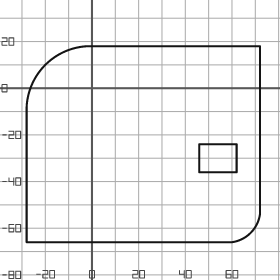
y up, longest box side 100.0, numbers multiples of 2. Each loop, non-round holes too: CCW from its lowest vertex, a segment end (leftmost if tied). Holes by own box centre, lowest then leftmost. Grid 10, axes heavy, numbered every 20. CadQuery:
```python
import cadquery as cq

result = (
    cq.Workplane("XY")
    .moveTo(-28.0, -66.0)
    .lineTo(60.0, -66.0)
    .threePointArc((68.0, -62.0), (72.0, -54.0))
    .lineTo(72.0, 18.0)
    .lineTo(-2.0, 18.0)
    .threePointArc((-20.0, 10.0), (-28.0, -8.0))
    .close()
    .moveTo(46.0, -36.0)
    .lineTo(62.0, -36.0)
    .lineTo(62.0, -24.0)
    .lineTo(46.0, -24.0)
    .close()
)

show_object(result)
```